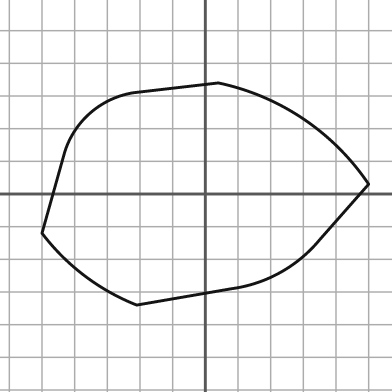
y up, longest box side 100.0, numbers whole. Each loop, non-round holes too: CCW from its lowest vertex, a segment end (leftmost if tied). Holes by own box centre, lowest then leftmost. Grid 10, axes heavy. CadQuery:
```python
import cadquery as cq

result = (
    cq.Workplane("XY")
    .moveTo(-21.0, -34.0)
    .lineTo(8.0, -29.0)
    .threePointArc((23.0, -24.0), (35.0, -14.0))
    .lineTo(50.0, 3.0)
    .threePointArc((30.0, 23.0), (4.0, 34.0))
    .lineTo(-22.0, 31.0)
    .threePointArc((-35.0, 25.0), (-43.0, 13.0))
    .lineTo(-50.0, -12.0)
    .threePointArc((-37.0, -25.0), (-21.0, -34.0))
    .close()
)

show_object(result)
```